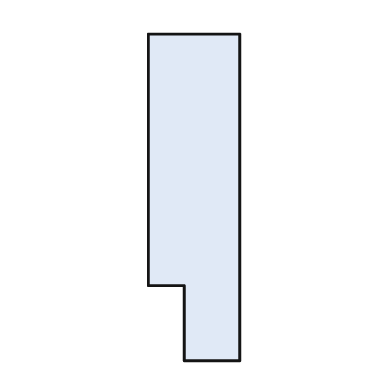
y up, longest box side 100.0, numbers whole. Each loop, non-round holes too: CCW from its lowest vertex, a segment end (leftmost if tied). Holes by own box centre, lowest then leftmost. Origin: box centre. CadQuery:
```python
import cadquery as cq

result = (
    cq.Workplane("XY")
    .moveTo(-3.0, -50.0)
    .lineTo(14.0, -50.0)
    .lineTo(14.0, 50.0)
    .lineTo(-14.0, 50.0)
    .lineTo(-14.0, -27.0)
    .lineTo(-3.0, -27.0)
    .close()
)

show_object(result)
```